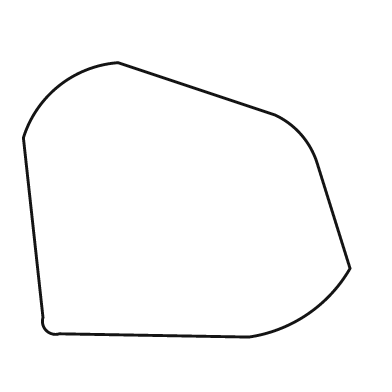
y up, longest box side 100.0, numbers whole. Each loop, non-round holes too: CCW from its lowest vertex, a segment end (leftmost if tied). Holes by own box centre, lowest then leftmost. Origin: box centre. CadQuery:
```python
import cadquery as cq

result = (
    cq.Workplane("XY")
    .moveTo(19.0, -42.0)
    .threePointArc((37.0, -35.0), (50.0, -21.0))
    .lineTo(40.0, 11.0)
    .threePointArc((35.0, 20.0), (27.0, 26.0))
    .lineTo(-21.0, 42.0)
    .threePointArc((-39.0, 35.0), (-50.0, 19.0))
    .lineTo(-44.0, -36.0)
    .threePointArc((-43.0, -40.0), (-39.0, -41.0))
    .close()
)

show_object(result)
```